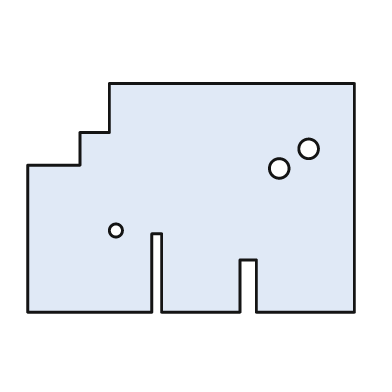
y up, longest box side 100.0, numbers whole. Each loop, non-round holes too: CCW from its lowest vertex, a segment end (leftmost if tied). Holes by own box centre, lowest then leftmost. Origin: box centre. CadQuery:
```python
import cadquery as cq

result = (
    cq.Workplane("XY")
    .moveTo(-50.0, -35.0)
    .lineTo(-12.0, -35.0)
    .lineTo(-12.0, -11.0)
    .lineTo(-9.0, -11.0)
    .lineTo(-9.0, -35.0)
    .lineTo(15.0, -35.0)
    .lineTo(15.0, -19.0)
    .lineTo(20.0, -19.0)
    .lineTo(20.0, -35.0)
    .lineTo(50.0, -35.0)
    .lineTo(50.0, 35.0)
    .lineTo(-25.0, 35.0)
    .lineTo(-25.0, 20.0)
    .lineTo(-34.0, 20.0)
    .lineTo(-34.0, 10.0)
    .lineTo(-50.0, 10.0)
    .close()
    .moveTo(-23.0, -10.0)
    .circle(2.0)
    .moveTo(27.0, 9.0)
    .circle(3.0)
    .moveTo(36.0, 15.0)
    .circle(3.0)
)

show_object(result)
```